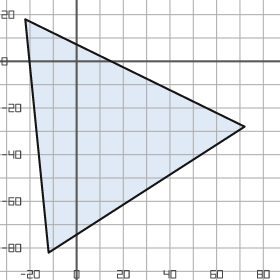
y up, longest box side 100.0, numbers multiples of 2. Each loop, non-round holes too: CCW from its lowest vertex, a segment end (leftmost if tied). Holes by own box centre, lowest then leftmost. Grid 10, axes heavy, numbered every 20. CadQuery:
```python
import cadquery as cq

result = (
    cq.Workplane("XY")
    .moveTo(-12.0, -82.0)
    .lineTo(72.0, -28.0)
    .lineTo(-22.0, 18.0)
    .close()
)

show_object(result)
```